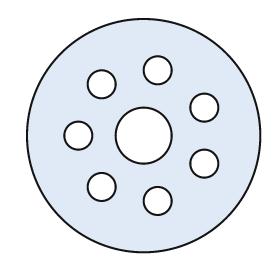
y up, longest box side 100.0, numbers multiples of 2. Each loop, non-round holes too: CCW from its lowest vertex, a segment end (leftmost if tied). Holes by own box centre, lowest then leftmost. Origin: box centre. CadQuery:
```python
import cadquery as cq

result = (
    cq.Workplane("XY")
    .moveTo(0.0, 0.0)
    .circle(50.0)
    .moveTo(6.0, -28.0)
    .circle(6.0)
    .moveTo(-18.0, -22.0)
    .circle(6.0)
    .moveTo(26.0, -12.0)
    .circle(6.0)
    .moveTo(-28.0, 0.0)
    .circle(6.0)
    .moveTo(0.0, 0.0)
    .circle(12.0)
    .moveTo(26.0, 12.0)
    .circle(6.0)
    .moveTo(-18.0, 22.0)
    .circle(6.0)
    .moveTo(6.0, 28.0)
    .circle(6.0)
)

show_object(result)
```